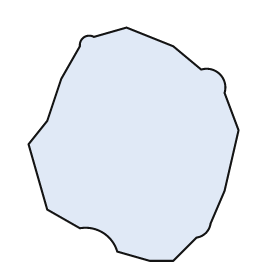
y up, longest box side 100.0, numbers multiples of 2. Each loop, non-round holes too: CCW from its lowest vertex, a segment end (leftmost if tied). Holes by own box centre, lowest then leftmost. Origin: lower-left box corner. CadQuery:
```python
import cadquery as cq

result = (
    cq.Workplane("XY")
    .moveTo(52.0, 0.0)
    .lineTo(62.0, 0.0)
    .lineTo(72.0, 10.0)
    .threePointArc((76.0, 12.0), (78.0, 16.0))
    .lineTo(84.0, 30.0)
    .lineTo(90.0, 56.0)
    .lineTo(84.0, 72.0)
    .threePointArc((82.0, 80.0), (74.0, 82.0))
    .lineTo(62.0, 92.0)
    .lineTo(42.0, 100.0)
    .lineTo(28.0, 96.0)
    .threePointArc((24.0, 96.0), (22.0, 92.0))
    .lineTo(14.0, 78.0)
    .lineTo(8.0, 60.0)
    .lineTo(0.0, 50.0)
    .lineTo(8.0, 22.0)
    .lineTo(22.0, 14.0)
    .threePointArc((32.0, 12.0), (38.0, 4.0))
    .close()
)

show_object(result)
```